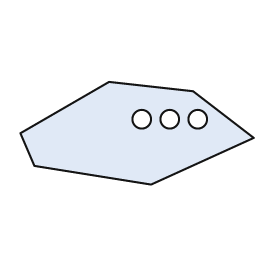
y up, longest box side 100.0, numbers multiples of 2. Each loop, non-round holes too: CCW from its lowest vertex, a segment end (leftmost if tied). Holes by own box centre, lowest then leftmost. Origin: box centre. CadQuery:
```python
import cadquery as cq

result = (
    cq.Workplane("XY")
    .moveTo(6.0, -22.0)
    .lineTo(50.0, -2.0)
    .lineTo(24.0, 18.0)
    .lineTo(-12.0, 22.0)
    .lineTo(-50.0, 0.0)
    .lineTo(-44.0, -14.0)
    .close()
    .moveTo(2.0, 6.0)
    .circle(4.0)
    .moveTo(14.0, 6.0)
    .circle(4.0)
    .moveTo(26.0, 6.0)
    .circle(4.0)
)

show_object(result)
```